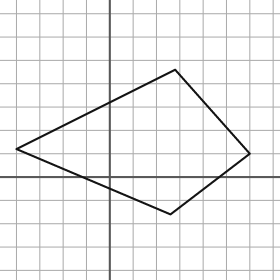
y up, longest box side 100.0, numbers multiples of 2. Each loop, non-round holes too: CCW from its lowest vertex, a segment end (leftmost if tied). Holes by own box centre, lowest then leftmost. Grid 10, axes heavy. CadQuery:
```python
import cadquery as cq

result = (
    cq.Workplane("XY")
    .moveTo(26.0, -16.0)
    .lineTo(60.0, 10.0)
    .lineTo(28.0, 46.0)
    .lineTo(-40.0, 12.0)
    .close()
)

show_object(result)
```